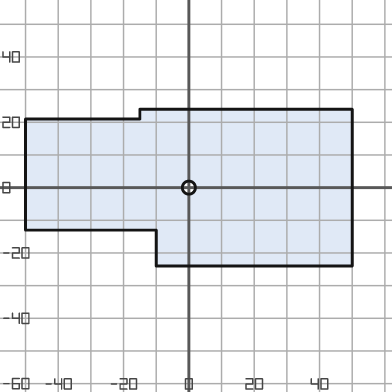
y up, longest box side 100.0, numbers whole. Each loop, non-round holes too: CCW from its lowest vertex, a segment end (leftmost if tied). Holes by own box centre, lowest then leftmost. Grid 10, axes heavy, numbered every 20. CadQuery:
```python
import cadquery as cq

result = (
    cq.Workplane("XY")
    .moveTo(-10.0, -24.0)
    .lineTo(50.0, -24.0)
    .lineTo(50.0, 24.0)
    .lineTo(-15.0, 24.0)
    .lineTo(-15.0, 21.0)
    .lineTo(-50.0, 21.0)
    .lineTo(-50.0, -13.0)
    .lineTo(-10.0, -13.0)
    .close()
    .moveTo(0.0, 0.0)
    .circle(2.0)
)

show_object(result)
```